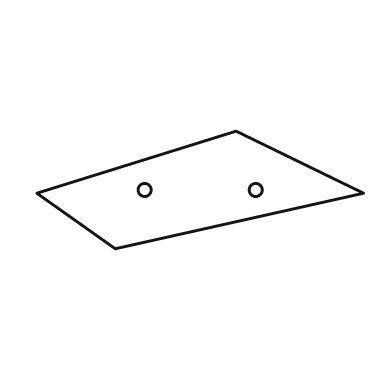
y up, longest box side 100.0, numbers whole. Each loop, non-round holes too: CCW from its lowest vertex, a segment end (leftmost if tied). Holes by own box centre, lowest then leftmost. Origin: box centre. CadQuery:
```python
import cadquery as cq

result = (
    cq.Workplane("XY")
    .moveTo(-26.0, -18.0)
    .lineTo(50.0, -1.0)
    .lineTo(11.0, 18.0)
    .lineTo(-50.0, -1.0)
    .close()
    .moveTo(-17.0, 0.0)
    .circle(2.0)
    .moveTo(17.0, 0.0)
    .circle(2.0)
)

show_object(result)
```